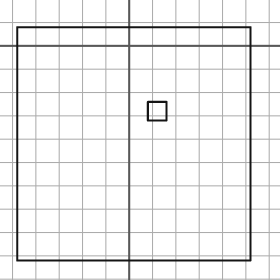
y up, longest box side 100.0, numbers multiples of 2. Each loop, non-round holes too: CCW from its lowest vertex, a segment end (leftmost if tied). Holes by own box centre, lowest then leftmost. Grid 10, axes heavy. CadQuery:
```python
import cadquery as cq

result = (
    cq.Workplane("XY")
    .moveTo(-48.0, -92.0)
    .lineTo(52.0, -92.0)
    .lineTo(52.0, 8.0)
    .lineTo(-48.0, 8.0)
    .close()
    .moveTo(8.0, -32.0)
    .lineTo(16.0, -32.0)
    .lineTo(16.0, -24.0)
    .lineTo(8.0, -24.0)
    .close()
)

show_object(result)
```